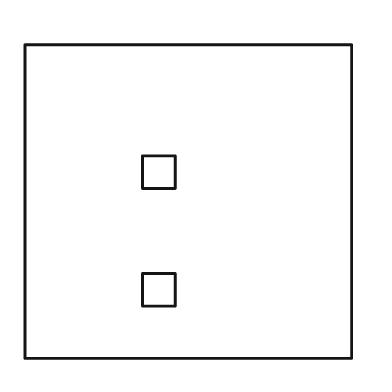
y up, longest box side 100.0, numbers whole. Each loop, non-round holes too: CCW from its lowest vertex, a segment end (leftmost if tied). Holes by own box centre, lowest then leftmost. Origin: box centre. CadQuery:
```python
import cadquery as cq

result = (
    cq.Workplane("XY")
    .moveTo(-50.0, -48.0)
    .lineTo(50.0, -48.0)
    .lineTo(50.0, 48.0)
    .lineTo(-50.0, 48.0)
    .close()
    .moveTo(-14.0, -32.0)
    .lineTo(-4.0, -32.0)
    .lineTo(-4.0, -22.0)
    .lineTo(-14.0, -22.0)
    .close()
    .moveTo(-14.0, 4.0)
    .lineTo(-4.0, 4.0)
    .lineTo(-4.0, 14.0)
    .lineTo(-14.0, 14.0)
    .close()
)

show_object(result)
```